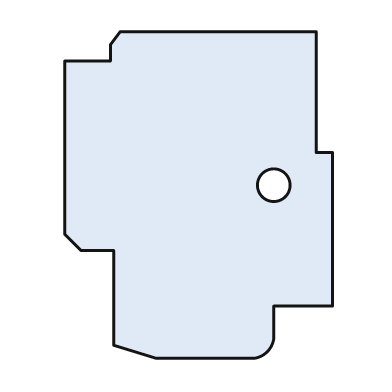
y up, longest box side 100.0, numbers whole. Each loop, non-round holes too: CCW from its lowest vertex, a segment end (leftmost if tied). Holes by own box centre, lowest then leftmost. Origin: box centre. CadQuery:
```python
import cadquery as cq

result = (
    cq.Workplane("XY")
    .moveTo(-13.0, -50.0)
    .lineTo(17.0, -50.0)
    .threePointArc((21.0, -48.0), (23.0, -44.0))
    .lineTo(23.0, -34.0)
    .lineTo(41.0, -34.0)
    .lineTo(41.0, 13.0)
    .lineTo(36.0, 13.0)
    .lineTo(36.0, 50.0)
    .lineTo(-24.0, 50.0)
    .lineTo(-27.0, 46.0)
    .lineTo(-27.0, 41.0)
    .lineTo(-41.0, 41.0)
    .lineTo(-41.0, -12.0)
    .lineTo(-36.0, -17.0)
    .lineTo(-26.0, -17.0)
    .lineTo(-26.0, -46.0)
    .close()
    .moveTo(23.0, 3.0)
    .circle(5.0)
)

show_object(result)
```